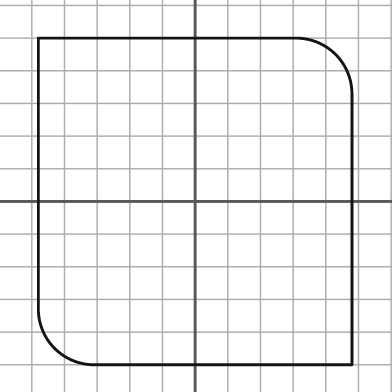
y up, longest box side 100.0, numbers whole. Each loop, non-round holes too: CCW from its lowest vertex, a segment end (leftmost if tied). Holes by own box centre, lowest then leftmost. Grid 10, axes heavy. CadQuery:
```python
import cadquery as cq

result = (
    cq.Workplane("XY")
    .moveTo(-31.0, -50.0)
    .lineTo(48.0, -50.0)
    .lineTo(48.0, 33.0)
    .threePointArc((43.0, 45.0), (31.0, 50.0))
    .lineTo(-48.0, 50.0)
    .lineTo(-48.0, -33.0)
    .threePointArc((-43.0, -45.0), (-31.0, -50.0))
    .close()
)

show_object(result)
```